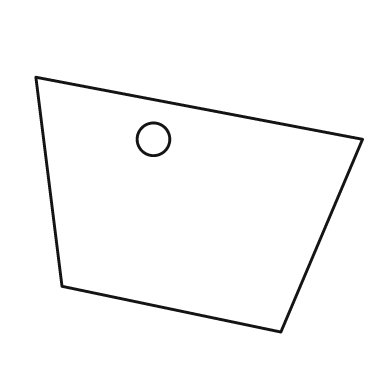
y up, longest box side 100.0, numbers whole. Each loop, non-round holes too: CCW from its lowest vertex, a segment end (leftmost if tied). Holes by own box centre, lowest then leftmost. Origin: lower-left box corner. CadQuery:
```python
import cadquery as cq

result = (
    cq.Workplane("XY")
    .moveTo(75.0, 0.0)
    .lineTo(100.0, 59.0)
    .lineTo(0.0, 78.0)
    .lineTo(8.0, 14.0)
    .close()
    .moveTo(36.0, 59.0)
    .circle(5.0)
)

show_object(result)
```